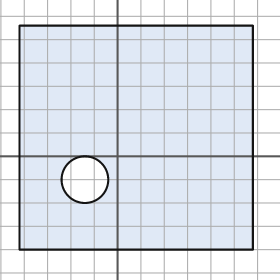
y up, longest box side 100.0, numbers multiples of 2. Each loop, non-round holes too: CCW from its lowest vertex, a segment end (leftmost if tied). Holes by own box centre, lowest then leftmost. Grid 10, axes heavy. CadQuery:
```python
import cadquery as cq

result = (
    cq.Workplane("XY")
    .moveTo(-42.0, -40.0)
    .lineTo(58.0, -40.0)
    .lineTo(58.0, 56.0)
    .lineTo(-42.0, 56.0)
    .close()
    .moveTo(-14.0, -10.0)
    .circle(10.0)
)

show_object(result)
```